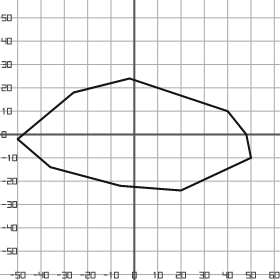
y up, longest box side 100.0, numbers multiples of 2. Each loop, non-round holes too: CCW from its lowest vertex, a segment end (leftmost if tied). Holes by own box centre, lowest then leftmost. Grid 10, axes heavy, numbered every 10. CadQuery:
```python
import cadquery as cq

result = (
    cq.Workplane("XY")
    .moveTo(20.0, -24.0)
    .lineTo(50.0, -10.0)
    .lineTo(48.0, 0.0)
    .lineTo(40.0, 10.0)
    .lineTo(-2.0, 24.0)
    .lineTo(-26.0, 18.0)
    .lineTo(-50.0, -2.0)
    .lineTo(-36.0, -14.0)
    .lineTo(-6.0, -22.0)
    .close()
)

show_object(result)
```